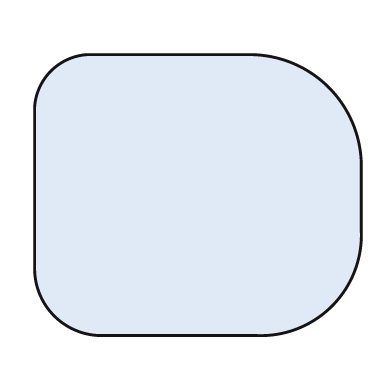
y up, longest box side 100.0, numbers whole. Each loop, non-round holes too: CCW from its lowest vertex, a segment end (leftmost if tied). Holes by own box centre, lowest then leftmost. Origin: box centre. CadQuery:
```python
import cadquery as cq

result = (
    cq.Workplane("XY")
    .moveTo(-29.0, -43.0)
    .lineTo(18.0, -43.0)
    .threePointArc((41.0, -34.0), (50.0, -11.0))
    .lineTo(50.0, 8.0)
    .threePointArc((40.0, 33.0), (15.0, 43.0))
    .lineTo(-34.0, 43.0)
    .threePointArc((-45.0, 38.0), (-50.0, 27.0))
    .lineTo(-50.0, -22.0)
    .threePointArc((-44.0, -37.0), (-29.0, -43.0))
    .close()
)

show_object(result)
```